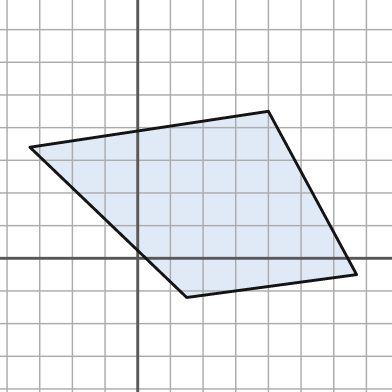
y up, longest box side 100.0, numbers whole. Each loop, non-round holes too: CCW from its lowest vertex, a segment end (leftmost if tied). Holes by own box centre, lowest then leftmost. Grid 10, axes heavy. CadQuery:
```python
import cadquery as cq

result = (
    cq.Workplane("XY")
    .moveTo(15.0, -12.0)
    .lineTo(67.0, -5.0)
    .lineTo(40.0, 45.0)
    .lineTo(-33.0, 34.0)
    .close()
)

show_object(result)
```